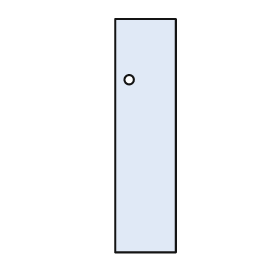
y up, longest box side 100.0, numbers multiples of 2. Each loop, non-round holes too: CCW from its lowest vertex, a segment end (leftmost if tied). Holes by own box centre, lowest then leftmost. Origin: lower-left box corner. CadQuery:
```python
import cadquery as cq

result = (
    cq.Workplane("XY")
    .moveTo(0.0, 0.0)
    .lineTo(26.0, 0.0)
    .lineTo(26.0, 100.0)
    .lineTo(0.0, 100.0)
    .close()
    .moveTo(6.0, 74.0)
    .circle(2.0)
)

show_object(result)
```